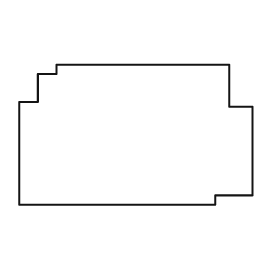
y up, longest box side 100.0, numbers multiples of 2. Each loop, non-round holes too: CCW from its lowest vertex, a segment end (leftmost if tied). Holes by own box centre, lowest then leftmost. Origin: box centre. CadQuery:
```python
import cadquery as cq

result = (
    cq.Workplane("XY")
    .moveTo(-50.0, -30.0)
    .lineTo(34.0, -30.0)
    .lineTo(34.0, -26.0)
    .lineTo(50.0, -26.0)
    .lineTo(50.0, 12.0)
    .lineTo(40.0, 12.0)
    .lineTo(40.0, 30.0)
    .lineTo(-34.0, 30.0)
    .lineTo(-34.0, 26.0)
    .lineTo(-42.0, 26.0)
    .lineTo(-42.0, 14.0)
    .lineTo(-50.0, 14.0)
    .close()
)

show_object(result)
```